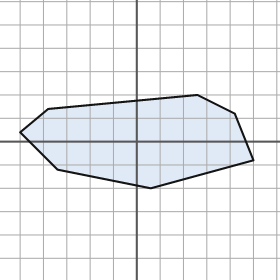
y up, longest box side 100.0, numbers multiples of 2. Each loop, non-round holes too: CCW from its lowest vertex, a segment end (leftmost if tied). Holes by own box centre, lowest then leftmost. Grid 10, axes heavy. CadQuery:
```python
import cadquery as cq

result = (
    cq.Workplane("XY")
    .moveTo(6.0, -20.0)
    .lineTo(50.0, -8.0)
    .lineTo(42.0, 12.0)
    .lineTo(26.0, 20.0)
    .lineTo(-38.0, 14.0)
    .lineTo(-50.0, 4.0)
    .lineTo(-34.0, -12.0)
    .close()
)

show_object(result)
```